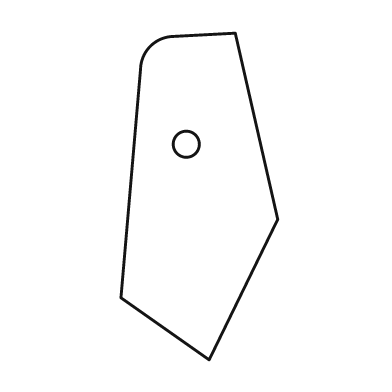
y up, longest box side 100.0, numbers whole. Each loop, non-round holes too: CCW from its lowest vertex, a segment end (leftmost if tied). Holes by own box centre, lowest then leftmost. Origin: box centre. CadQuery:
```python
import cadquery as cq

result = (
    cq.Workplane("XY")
    .moveTo(3.0, -50.0)
    .lineTo(24.0, -7.0)
    .lineTo(11.0, 50.0)
    .lineTo(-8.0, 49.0)
    .threePointArc((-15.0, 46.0), (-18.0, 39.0))
    .lineTo(-24.0, -31.0)
    .close()
    .moveTo(-4.0, 16.0)
    .circle(4.0)
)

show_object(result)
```